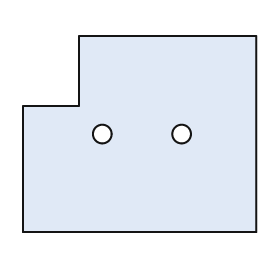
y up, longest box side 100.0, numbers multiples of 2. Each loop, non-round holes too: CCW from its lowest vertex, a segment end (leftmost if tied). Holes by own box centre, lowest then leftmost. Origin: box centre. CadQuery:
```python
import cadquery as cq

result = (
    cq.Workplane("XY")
    .moveTo(-50.0, -42.0)
    .lineTo(50.0, -42.0)
    .lineTo(50.0, 42.0)
    .lineTo(-26.0, 42.0)
    .lineTo(-26.0, 12.0)
    .lineTo(-50.0, 12.0)
    .close()
    .moveTo(-16.0, 0.0)
    .circle(4.0)
    .moveTo(18.0, 0.0)
    .circle(4.0)
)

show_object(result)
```